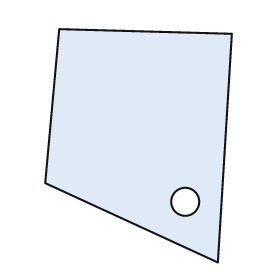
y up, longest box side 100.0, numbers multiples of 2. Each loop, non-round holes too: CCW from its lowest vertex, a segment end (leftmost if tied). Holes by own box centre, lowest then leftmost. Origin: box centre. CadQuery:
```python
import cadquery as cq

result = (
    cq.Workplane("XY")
    .moveTo(34.0, -50.0)
    .lineTo(40.0, 48.0)
    .lineTo(-34.0, 50.0)
    .lineTo(-40.0, -16.0)
    .close()
    .moveTo(20.0, -24.0)
    .circle(6.0)
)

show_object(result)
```